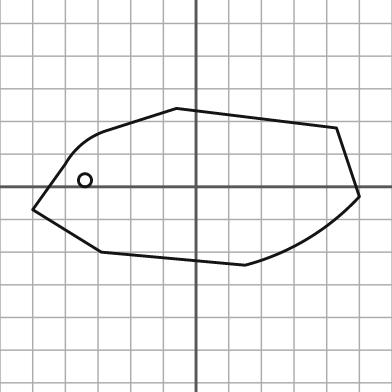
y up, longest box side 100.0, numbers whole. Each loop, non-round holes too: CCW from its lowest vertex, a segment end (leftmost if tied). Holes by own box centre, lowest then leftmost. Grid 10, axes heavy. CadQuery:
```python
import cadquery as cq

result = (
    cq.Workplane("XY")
    .moveTo(15.0, -24.0)
    .threePointArc((34.0, -16.0), (50.0, -3.0))
    .lineTo(43.0, 18.0)
    .lineTo(-6.0, 24.0)
    .lineTo(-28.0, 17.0)
    .threePointArc((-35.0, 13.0), (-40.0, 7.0))
    .lineTo(-50.0, -7.0)
    .lineTo(-29.0, -20.0)
    .close()
    .moveTo(-34.0, 2.0)
    .circle(2.0)
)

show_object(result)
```